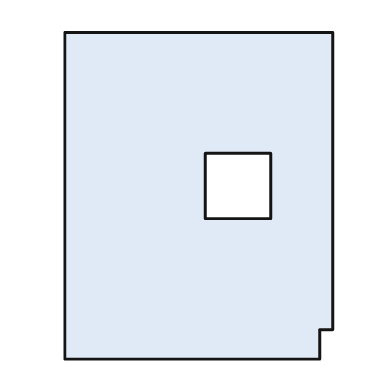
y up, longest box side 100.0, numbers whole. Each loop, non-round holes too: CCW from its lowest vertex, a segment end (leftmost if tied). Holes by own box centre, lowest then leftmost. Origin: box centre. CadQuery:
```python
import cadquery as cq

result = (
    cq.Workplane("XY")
    .moveTo(-41.0, -50.0)
    .lineTo(37.0, -50.0)
    .lineTo(37.0, -41.0)
    .lineTo(41.0, -41.0)
    .lineTo(41.0, 50.0)
    .lineTo(-41.0, 50.0)
    .close()
    .moveTo(2.0, -7.0)
    .lineTo(22.0, -7.0)
    .lineTo(22.0, 13.0)
    .lineTo(2.0, 13.0)
    .close()
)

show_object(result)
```